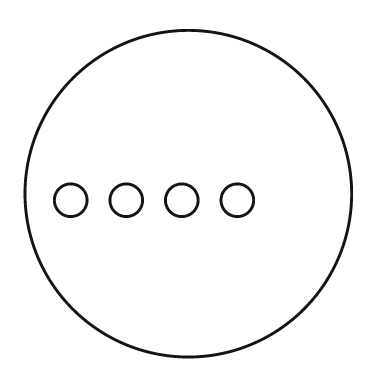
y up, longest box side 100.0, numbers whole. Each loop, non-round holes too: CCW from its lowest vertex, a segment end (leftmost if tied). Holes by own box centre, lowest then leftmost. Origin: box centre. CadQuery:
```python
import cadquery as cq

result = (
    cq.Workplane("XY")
    .moveTo(0.0, 0.0)
    .circle(50.0)
    .moveTo(-36.0, -2.0)
    .circle(5.0)
    .moveTo(-19.0, -2.0)
    .circle(5.0)
    .moveTo(-2.0, -2.0)
    .circle(5.0)
    .moveTo(15.0, -2.0)
    .circle(5.0)
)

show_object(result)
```